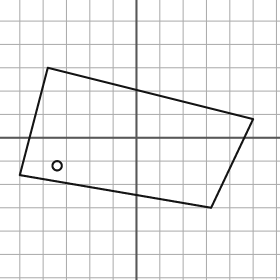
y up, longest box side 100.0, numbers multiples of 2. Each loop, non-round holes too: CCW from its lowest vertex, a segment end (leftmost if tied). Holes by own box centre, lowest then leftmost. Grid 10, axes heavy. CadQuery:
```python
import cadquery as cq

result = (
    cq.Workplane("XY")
    .moveTo(32.0, -30.0)
    .lineTo(50.0, 8.0)
    .lineTo(-38.0, 30.0)
    .lineTo(-50.0, -16.0)
    .close()
    .moveTo(-34.0, -12.0)
    .circle(2.0)
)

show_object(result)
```